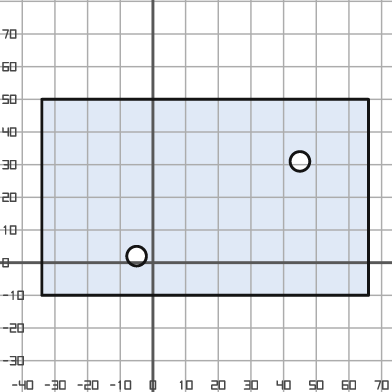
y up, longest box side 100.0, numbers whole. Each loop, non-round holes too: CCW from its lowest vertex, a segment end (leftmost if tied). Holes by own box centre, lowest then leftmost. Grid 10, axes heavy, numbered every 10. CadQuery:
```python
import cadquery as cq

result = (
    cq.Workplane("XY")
    .moveTo(-34.0, -10.0)
    .lineTo(66.0, -10.0)
    .lineTo(66.0, 50.0)
    .lineTo(-34.0, 50.0)
    .close()
    .moveTo(-5.0, 2.0)
    .circle(3.0)
    .moveTo(45.0, 31.0)
    .circle(3.0)
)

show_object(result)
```